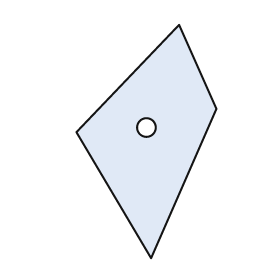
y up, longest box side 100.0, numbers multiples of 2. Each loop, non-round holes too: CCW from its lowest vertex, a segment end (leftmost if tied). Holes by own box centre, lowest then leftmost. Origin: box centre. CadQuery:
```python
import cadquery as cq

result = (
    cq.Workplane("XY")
    .moveTo(2.0, -50.0)
    .lineTo(30.0, 14.0)
    .lineTo(14.0, 50.0)
    .lineTo(-30.0, 4.0)
    .close()
    .moveTo(0.0, 6.0)
    .circle(4.0)
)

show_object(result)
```